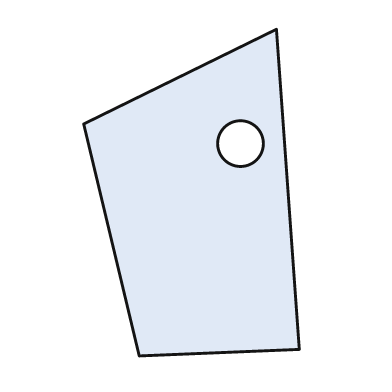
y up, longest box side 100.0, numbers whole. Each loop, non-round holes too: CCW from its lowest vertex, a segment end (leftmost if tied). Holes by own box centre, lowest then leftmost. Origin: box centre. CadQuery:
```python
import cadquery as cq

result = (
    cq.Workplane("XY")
    .moveTo(-16.0, -50.0)
    .lineTo(33.0, -48.0)
    .lineTo(26.0, 50.0)
    .lineTo(-33.0, 21.0)
    .close()
    .moveTo(15.0, 15.0)
    .circle(7.0)
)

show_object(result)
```